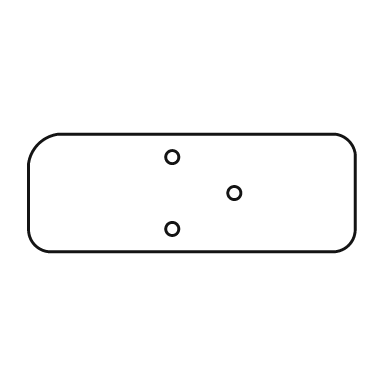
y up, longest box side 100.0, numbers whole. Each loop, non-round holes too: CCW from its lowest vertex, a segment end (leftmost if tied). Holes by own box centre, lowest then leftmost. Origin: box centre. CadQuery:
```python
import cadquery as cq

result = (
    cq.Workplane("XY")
    .moveTo(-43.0, -18.0)
    .lineTo(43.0, -18.0)
    .threePointArc((48.0, -16.0), (50.0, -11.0))
    .lineTo(50.0, 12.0)
    .threePointArc((48.0, 16.0), (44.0, 18.0))
    .lineTo(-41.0, 18.0)
    .threePointArc((-47.0, 15.0), (-50.0, 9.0))
    .lineTo(-50.0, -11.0)
    .threePointArc((-48.0, -16.0), (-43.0, -18.0))
    .close()
    .moveTo(-6.0, -11.0)
    .circle(2.0)
    .moveTo(13.0, 0.0)
    .circle(2.0)
    .moveTo(-6.0, 11.0)
    .circle(2.0)
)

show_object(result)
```